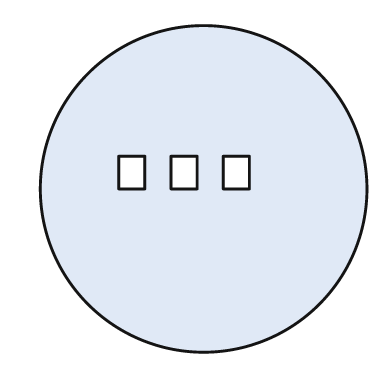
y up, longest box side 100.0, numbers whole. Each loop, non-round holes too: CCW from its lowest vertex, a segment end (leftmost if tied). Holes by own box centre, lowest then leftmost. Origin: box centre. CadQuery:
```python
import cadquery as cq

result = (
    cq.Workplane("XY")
    .moveTo(0.0, 0.0)
    .circle(50.0)
    .moveTo(-26.0, 0.0)
    .lineTo(-18.0, 0.0)
    .lineTo(-18.0, 10.0)
    .lineTo(-26.0, 10.0)
    .close()
    .moveTo(-10.0, 0.0)
    .lineTo(-2.0, 0.0)
    .lineTo(-2.0, 10.0)
    .lineTo(-10.0, 10.0)
    .close()
    .moveTo(6.0, 0.0)
    .lineTo(14.0, 0.0)
    .lineTo(14.0, 10.0)
    .lineTo(6.0, 10.0)
    .close()
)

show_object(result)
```